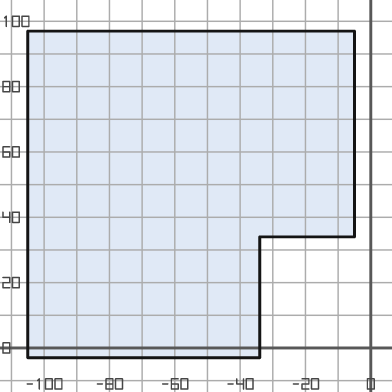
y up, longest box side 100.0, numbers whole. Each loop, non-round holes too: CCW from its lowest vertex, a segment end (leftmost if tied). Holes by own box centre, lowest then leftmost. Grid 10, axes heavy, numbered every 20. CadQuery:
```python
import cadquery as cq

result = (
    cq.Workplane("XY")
    .moveTo(-105.0, -3.0)
    .lineTo(-34.0, -3.0)
    .lineTo(-34.0, 34.0)
    .lineTo(-5.0, 34.0)
    .lineTo(-5.0, 97.0)
    .lineTo(-105.0, 97.0)
    .close()
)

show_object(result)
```